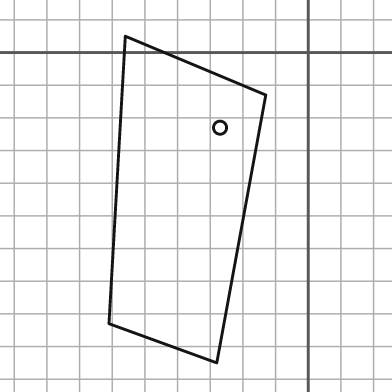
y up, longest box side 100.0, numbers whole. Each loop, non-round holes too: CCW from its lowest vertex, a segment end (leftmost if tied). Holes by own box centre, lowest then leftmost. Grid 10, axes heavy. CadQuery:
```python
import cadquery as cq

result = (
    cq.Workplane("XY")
    .moveTo(-28.0, -95.0)
    .lineTo(-13.0, -13.0)
    .lineTo(-56.0, 5.0)
    .lineTo(-61.0, -83.0)
    .close()
    .moveTo(-27.0, -23.0)
    .circle(2.0)
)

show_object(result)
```